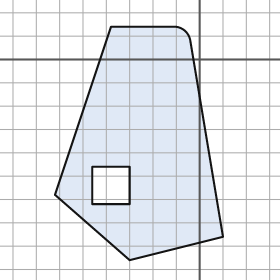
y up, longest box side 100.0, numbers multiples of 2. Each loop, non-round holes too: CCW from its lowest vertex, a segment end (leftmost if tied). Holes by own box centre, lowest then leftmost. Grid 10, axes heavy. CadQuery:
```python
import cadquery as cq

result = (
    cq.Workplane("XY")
    .moveTo(-30.0, -86.0)
    .lineTo(10.0, -76.0)
    .lineTo(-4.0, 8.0)
    .threePointArc((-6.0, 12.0), (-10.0, 14.0))
    .lineTo(-38.0, 14.0)
    .lineTo(-62.0, -58.0)
    .close()
    .moveTo(-46.0, -62.0)
    .lineTo(-30.0, -62.0)
    .lineTo(-30.0, -46.0)
    .lineTo(-46.0, -46.0)
    .close()
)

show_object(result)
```